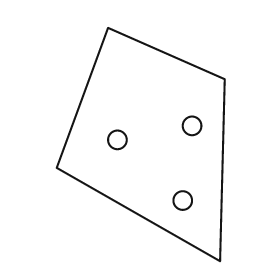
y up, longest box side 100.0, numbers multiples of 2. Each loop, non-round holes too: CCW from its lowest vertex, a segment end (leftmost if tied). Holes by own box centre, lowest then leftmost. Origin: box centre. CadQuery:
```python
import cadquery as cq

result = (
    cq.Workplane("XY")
    .moveTo(34.0, -50.0)
    .lineTo(36.0, 28.0)
    .lineTo(-14.0, 50.0)
    .lineTo(-36.0, -10.0)
    .close()
    .moveTo(18.0, -24.0)
    .circle(4.0)
    .moveTo(-10.0, 2.0)
    .circle(4.0)
    .moveTo(22.0, 8.0)
    .circle(4.0)
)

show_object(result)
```